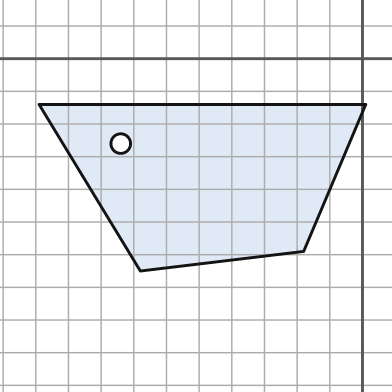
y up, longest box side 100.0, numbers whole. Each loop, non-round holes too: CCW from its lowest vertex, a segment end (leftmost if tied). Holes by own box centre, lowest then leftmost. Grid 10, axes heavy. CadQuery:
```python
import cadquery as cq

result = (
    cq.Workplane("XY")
    .moveTo(-68.0, -65.0)
    .lineTo(-18.0, -59.0)
    .lineTo(1.0, -14.0)
    .lineTo(-99.0, -14.0)
    .close()
    .moveTo(-74.0, -26.0)
    .circle(3.0)
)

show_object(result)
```